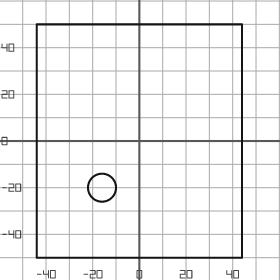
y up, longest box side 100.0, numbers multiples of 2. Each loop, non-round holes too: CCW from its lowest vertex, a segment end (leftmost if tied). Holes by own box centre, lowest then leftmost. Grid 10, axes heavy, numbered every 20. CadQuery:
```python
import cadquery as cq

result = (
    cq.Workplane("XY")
    .moveTo(-44.0, -50.0)
    .lineTo(44.0, -50.0)
    .lineTo(44.0, 50.0)
    .lineTo(-44.0, 50.0)
    .close()
    .moveTo(-16.0, -20.0)
    .circle(6.0)
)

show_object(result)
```